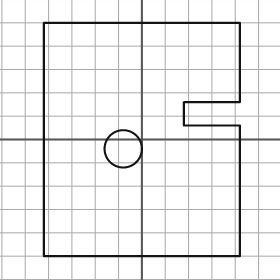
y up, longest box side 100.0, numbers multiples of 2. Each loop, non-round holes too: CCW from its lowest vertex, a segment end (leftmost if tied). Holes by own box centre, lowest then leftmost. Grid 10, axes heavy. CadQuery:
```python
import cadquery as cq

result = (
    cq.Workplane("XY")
    .moveTo(-42.0, -50.0)
    .lineTo(42.0, -50.0)
    .lineTo(42.0, 6.0)
    .lineTo(18.0, 6.0)
    .lineTo(18.0, 16.0)
    .lineTo(42.0, 16.0)
    .lineTo(42.0, 50.0)
    .lineTo(-42.0, 50.0)
    .close()
    .moveTo(-8.0, -4.0)
    .circle(8.0)
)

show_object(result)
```